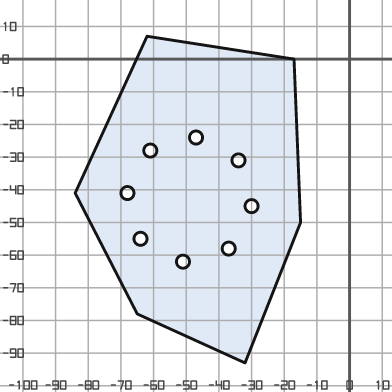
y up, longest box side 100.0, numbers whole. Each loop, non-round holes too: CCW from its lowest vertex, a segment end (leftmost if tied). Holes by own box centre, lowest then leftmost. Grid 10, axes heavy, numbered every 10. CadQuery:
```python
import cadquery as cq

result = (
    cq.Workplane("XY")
    .moveTo(-32.0, -93.0)
    .lineTo(-15.0, -50.0)
    .lineTo(-17.0, 0.0)
    .lineTo(-62.0, 7.0)
    .lineTo(-84.0, -41.0)
    .lineTo(-65.0, -78.0)
    .close()
    .moveTo(-51.0, -62.0)
    .circle(2.0)
    .moveTo(-37.0, -58.0)
    .circle(2.0)
    .moveTo(-64.0, -55.0)
    .circle(2.0)
    .moveTo(-30.0, -45.0)
    .circle(2.0)
    .moveTo(-68.0, -41.0)
    .circle(2.0)
    .moveTo(-34.0, -31.0)
    .circle(2.0)
    .moveTo(-61.0, -28.0)
    .circle(2.0)
    .moveTo(-47.0, -24.0)
    .circle(2.0)
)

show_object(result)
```